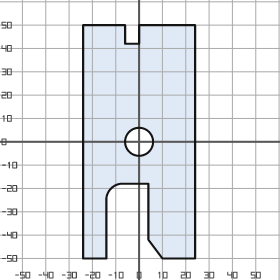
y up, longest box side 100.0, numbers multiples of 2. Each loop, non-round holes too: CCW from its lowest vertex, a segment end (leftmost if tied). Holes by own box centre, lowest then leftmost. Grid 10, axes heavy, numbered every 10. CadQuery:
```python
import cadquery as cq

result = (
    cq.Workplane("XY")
    .moveTo(-24.0, -50.0)
    .lineTo(-14.0, -50.0)
    .lineTo(-14.0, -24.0)
    .threePointArc((-12.0, -20.0), (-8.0, -18.0))
    .lineTo(4.0, -18.0)
    .lineTo(4.0, -42.0)
    .lineTo(10.0, -50.0)
    .lineTo(24.0, -50.0)
    .lineTo(24.0, 50.0)
    .lineTo(0.0, 50.0)
    .lineTo(0.0, 42.0)
    .lineTo(-6.0, 42.0)
    .lineTo(-6.0, 50.0)
    .lineTo(-24.0, 50.0)
    .close()
    .moveTo(0.0, 0.0)
    .circle(6.0)
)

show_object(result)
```